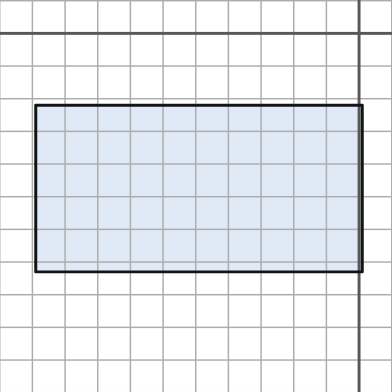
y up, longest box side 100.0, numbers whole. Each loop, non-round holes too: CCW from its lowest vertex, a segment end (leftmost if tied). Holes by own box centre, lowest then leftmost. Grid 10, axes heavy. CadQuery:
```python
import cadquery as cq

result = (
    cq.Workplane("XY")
    .moveTo(-99.0, -73.0)
    .lineTo(1.0, -73.0)
    .lineTo(1.0, -22.0)
    .lineTo(-99.0, -22.0)
    .close()
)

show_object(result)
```